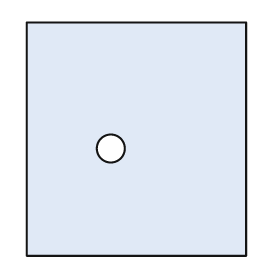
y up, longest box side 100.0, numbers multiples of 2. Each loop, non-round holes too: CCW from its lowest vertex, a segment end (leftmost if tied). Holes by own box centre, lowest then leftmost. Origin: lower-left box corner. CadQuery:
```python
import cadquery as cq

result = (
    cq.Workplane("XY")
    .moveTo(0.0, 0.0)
    .lineTo(94.0, 0.0)
    .lineTo(94.0, 100.0)
    .lineTo(0.0, 100.0)
    .close()
    .moveTo(36.0, 46.0)
    .circle(6.0)
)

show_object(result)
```